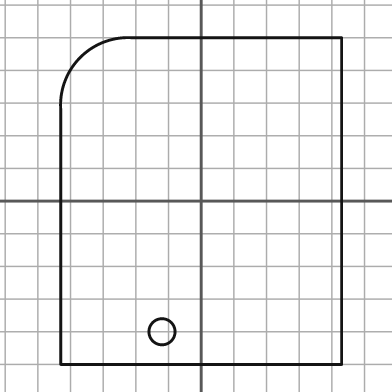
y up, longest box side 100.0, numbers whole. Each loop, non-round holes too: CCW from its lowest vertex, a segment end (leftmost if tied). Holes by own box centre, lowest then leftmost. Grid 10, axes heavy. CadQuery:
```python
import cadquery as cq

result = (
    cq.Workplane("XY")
    .moveTo(-43.0, -50.0)
    .lineTo(43.0, -50.0)
    .lineTo(43.0, 50.0)
    .lineTo(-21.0, 50.0)
    .threePointArc((-37.0, 44.0), (-43.0, 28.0))
    .close()
    .moveTo(-12.0, -40.0)
    .circle(4.0)
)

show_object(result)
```